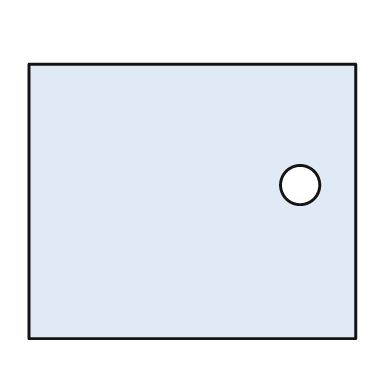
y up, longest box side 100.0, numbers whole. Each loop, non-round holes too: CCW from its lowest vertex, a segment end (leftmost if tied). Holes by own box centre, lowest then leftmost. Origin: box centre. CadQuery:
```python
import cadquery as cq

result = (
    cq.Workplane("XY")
    .moveTo(-50.0, -42.0)
    .lineTo(50.0, -42.0)
    .lineTo(50.0, 42.0)
    .lineTo(-50.0, 42.0)
    .close()
    .moveTo(33.0, 5.0)
    .circle(6.0)
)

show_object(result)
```